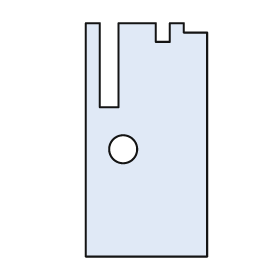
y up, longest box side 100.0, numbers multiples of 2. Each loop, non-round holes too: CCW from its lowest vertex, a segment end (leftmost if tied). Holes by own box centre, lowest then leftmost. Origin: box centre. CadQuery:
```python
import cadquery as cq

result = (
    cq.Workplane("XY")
    .moveTo(-26.0, -50.0)
    .lineTo(26.0, -50.0)
    .lineTo(26.0, 46.0)
    .lineTo(16.0, 46.0)
    .lineTo(16.0, 50.0)
    .lineTo(10.0, 50.0)
    .lineTo(10.0, 42.0)
    .lineTo(4.0, 42.0)
    .lineTo(4.0, 50.0)
    .lineTo(-12.0, 50.0)
    .lineTo(-12.0, 14.0)
    .lineTo(-20.0, 14.0)
    .lineTo(-20.0, 50.0)
    .lineTo(-26.0, 50.0)
    .close()
    .moveTo(-10.0, -4.0)
    .circle(6.0)
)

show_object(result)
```